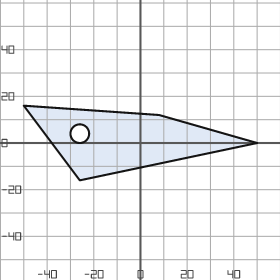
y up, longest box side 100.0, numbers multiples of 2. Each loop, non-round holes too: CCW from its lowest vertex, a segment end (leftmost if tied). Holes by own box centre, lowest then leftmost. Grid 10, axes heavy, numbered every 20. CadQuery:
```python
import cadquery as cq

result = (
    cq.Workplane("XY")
    .moveTo(-26.0, -16.0)
    .lineTo(50.0, 0.0)
    .lineTo(8.0, 12.0)
    .lineTo(-50.0, 16.0)
    .close()
    .moveTo(-26.0, 4.0)
    .circle(4.0)
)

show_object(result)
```